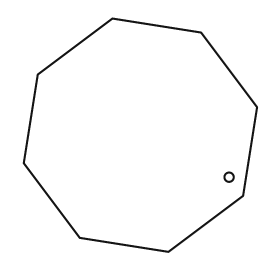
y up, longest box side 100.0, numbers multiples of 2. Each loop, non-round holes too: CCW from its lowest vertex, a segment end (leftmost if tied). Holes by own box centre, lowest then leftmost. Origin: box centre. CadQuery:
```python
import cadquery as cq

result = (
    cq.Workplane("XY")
    .moveTo(12.0, -50.0)
    .lineTo(44.0, -26.0)
    .lineTo(50.0, 12.0)
    .lineTo(26.0, 44.0)
    .lineTo(-12.0, 50.0)
    .lineTo(-44.0, 26.0)
    .lineTo(-50.0, -12.0)
    .lineTo(-26.0, -44.0)
    .close()
    .moveTo(38.0, -18.0)
    .circle(2.0)
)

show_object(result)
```